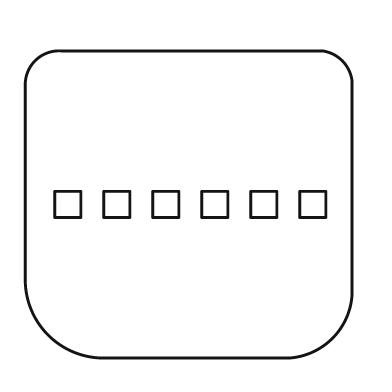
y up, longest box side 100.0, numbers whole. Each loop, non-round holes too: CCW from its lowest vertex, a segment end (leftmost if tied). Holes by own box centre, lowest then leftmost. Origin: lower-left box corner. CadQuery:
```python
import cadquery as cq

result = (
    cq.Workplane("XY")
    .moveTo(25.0, 0.0)
    .lineTo(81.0, 0.0)
    .threePointArc((94.0, 6.0), (100.0, 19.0))
    .lineTo(100.0, 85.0)
    .threePointArc((97.0, 91.0), (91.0, 94.0))
    .lineTo(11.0, 94.0)
    .threePointArc((3.0, 91.0), (0.0, 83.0))
    .lineTo(0.0, 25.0)
    .threePointArc((7.0, 7.0), (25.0, 0.0))
    .close()
    .moveTo(9.0, 43.0)
    .lineTo(17.0, 43.0)
    .lineTo(17.0, 51.0)
    .lineTo(9.0, 51.0)
    .close()
    .moveTo(24.0, 43.0)
    .lineTo(32.0, 43.0)
    .lineTo(32.0, 51.0)
    .lineTo(24.0, 51.0)
    .close()
    .moveTo(39.0, 43.0)
    .lineTo(47.0, 43.0)
    .lineTo(47.0, 51.0)
    .lineTo(39.0, 51.0)
    .close()
    .moveTo(54.0, 43.0)
    .lineTo(62.0, 43.0)
    .lineTo(62.0, 51.0)
    .lineTo(54.0, 51.0)
    .close()
    .moveTo(69.0, 43.0)
    .lineTo(77.0, 43.0)
    .lineTo(77.0, 51.0)
    .lineTo(69.0, 51.0)
    .close()
    .moveTo(84.0, 43.0)
    .lineTo(92.0, 43.0)
    .lineTo(92.0, 51.0)
    .lineTo(84.0, 51.0)
    .close()
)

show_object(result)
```